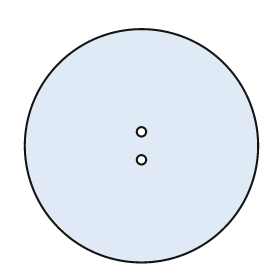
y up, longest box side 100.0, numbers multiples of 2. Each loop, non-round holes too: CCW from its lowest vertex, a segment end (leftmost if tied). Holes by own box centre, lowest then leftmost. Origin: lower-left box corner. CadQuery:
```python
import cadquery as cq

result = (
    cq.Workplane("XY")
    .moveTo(50.0, 50.0)
    .circle(50.0)
    .moveTo(50.0, 44.0)
    .circle(2.0)
    .moveTo(50.0, 56.0)
    .circle(2.0)
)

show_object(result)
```